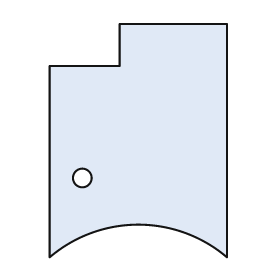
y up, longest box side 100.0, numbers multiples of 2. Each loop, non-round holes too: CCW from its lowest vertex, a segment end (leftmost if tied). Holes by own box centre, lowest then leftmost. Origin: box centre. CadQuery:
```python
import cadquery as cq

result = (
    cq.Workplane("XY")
    .moveTo(-38.0, -50.0)
    .threePointArc((0.0, -36.0), (38.0, -50.0))
    .lineTo(38.0, 50.0)
    .lineTo(-8.0, 50.0)
    .lineTo(-8.0, 32.0)
    .lineTo(-38.0, 32.0)
    .close()
    .moveTo(-24.0, -16.0)
    .circle(4.0)
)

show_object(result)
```